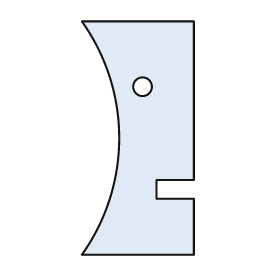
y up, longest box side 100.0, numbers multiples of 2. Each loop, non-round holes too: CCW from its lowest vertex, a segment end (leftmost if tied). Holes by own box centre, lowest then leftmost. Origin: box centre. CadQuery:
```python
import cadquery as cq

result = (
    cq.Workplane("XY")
    .moveTo(-24.0, -50.0)
    .lineTo(24.0, -50.0)
    .lineTo(24.0, -26.0)
    .lineTo(8.0, -26.0)
    .lineTo(8.0, -18.0)
    .lineTo(24.0, -18.0)
    .lineTo(24.0, 50.0)
    .lineTo(-24.0, 50.0)
    .threePointArc((-8.0, 0.0), (-24.0, -50.0))
    .close()
    .moveTo(2.0, 22.0)
    .circle(4.0)
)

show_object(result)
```